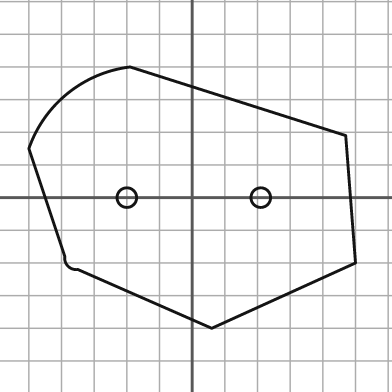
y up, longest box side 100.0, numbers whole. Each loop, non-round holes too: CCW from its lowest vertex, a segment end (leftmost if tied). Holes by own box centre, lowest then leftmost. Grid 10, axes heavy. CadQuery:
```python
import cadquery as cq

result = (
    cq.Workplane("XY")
    .moveTo(6.0, -40.0)
    .lineTo(50.0, -20.0)
    .lineTo(47.0, 19.0)
    .lineTo(-19.0, 40.0)
    .threePointArc((-38.0, 32.0), (-50.0, 15.0))
    .lineTo(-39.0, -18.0)
    .threePointArc((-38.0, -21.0), (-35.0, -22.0))
    .close()
    .moveTo(-20.0, 0.0)
    .circle(3.0)
    .moveTo(21.0, 0.0)
    .circle(3.0)
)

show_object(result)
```